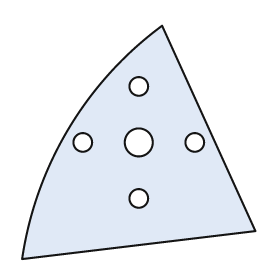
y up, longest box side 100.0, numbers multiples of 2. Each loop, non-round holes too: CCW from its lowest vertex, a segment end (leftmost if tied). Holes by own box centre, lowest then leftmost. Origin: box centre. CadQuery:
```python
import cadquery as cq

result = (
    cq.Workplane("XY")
    .moveTo(-50.0, -50.0)
    .lineTo(50.0, -38.0)
    .lineTo(10.0, 50.0)
    .threePointArc((-30.0, 6.0), (-50.0, -50.0))
    .close()
    .moveTo(0.0, -24.0)
    .circle(4.0)
    .moveTo(-24.0, 0.0)
    .circle(4.0)
    .moveTo(0.0, 0.0)
    .circle(6.0)
    .moveTo(24.0, 0.0)
    .circle(4.0)
    .moveTo(0.0, 24.0)
    .circle(4.0)
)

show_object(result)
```